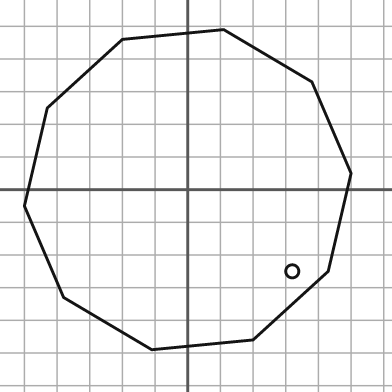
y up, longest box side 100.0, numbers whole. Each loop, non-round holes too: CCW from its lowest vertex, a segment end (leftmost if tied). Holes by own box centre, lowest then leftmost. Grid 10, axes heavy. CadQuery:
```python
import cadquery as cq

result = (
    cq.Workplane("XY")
    .moveTo(-11.0, -49.0)
    .lineTo(20.0, -46.0)
    .lineTo(43.0, -25.0)
    .lineTo(50.0, 5.0)
    .lineTo(38.0, 33.0)
    .lineTo(11.0, 49.0)
    .lineTo(-20.0, 46.0)
    .lineTo(-43.0, 25.0)
    .lineTo(-50.0, -5.0)
    .lineTo(-38.0, -33.0)
    .close()
    .moveTo(32.0, -25.0)
    .circle(2.0)
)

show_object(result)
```